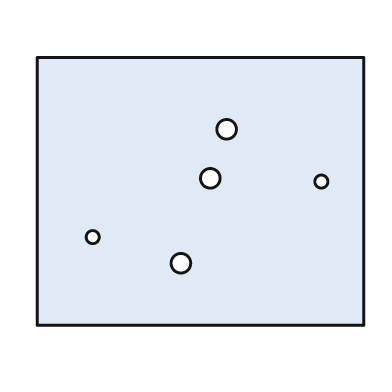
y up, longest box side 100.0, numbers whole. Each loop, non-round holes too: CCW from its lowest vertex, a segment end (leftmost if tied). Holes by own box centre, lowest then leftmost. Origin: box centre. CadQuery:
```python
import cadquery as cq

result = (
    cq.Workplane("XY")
    .moveTo(-50.0, -41.0)
    .lineTo(50.0, -41.0)
    .lineTo(50.0, 41.0)
    .lineTo(-50.0, 41.0)
    .close()
    .moveTo(-6.0, -22.0)
    .circle(3.0)
    .moveTo(-33.0, -14.0)
    .circle(2.0)
    .moveTo(37.0, 3.0)
    .circle(2.0)
    .moveTo(3.0, 4.0)
    .circle(3.0)
    .moveTo(8.0, 19.0)
    .circle(3.0)
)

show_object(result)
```